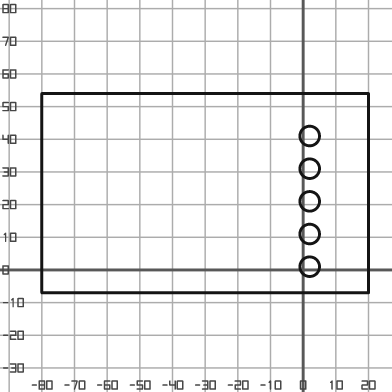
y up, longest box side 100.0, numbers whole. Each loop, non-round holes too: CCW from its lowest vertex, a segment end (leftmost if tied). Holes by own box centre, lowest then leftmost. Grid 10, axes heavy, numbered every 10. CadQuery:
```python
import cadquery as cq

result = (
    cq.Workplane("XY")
    .moveTo(-80.0, -7.0)
    .lineTo(20.0, -7.0)
    .lineTo(20.0, 54.0)
    .lineTo(-80.0, 54.0)
    .close()
    .moveTo(2.0, 1.0)
    .circle(3.0)
    .moveTo(2.0, 11.0)
    .circle(3.0)
    .moveTo(2.0, 21.0)
    .circle(3.0)
    .moveTo(2.0, 31.0)
    .circle(3.0)
    .moveTo(2.0, 41.0)
    .circle(3.0)
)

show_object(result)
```